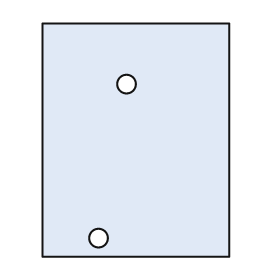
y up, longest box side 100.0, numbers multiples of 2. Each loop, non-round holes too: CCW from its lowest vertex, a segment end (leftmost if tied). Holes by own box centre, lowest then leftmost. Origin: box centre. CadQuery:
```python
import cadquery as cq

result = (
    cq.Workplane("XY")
    .moveTo(-40.0, -50.0)
    .lineTo(40.0, -50.0)
    .lineTo(40.0, 50.0)
    .lineTo(-40.0, 50.0)
    .close()
    .moveTo(-16.0, -42.0)
    .circle(4.0)
    .moveTo(-4.0, 24.0)
    .circle(4.0)
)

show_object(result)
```